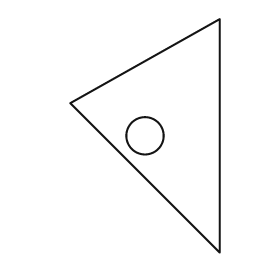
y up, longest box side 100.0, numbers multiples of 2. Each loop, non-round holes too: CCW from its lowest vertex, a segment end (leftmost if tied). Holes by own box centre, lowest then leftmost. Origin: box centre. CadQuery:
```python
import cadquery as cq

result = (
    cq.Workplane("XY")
    .moveTo(32.0, -50.0)
    .lineTo(32.0, 50.0)
    .lineTo(-32.0, 14.0)
    .close()
    .moveTo(0.0, 0.0)
    .circle(8.0)
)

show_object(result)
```